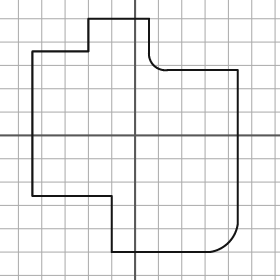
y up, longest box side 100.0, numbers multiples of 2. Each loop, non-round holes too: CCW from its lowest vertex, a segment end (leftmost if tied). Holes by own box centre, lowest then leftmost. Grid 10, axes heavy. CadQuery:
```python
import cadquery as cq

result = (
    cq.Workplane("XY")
    .moveTo(-10.0, -50.0)
    .lineTo(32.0, -50.0)
    .threePointArc((40.0, -46.0), (44.0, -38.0))
    .lineTo(44.0, 28.0)
    .lineTo(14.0, 28.0)
    .threePointArc((8.0, 30.0), (6.0, 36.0))
    .lineTo(6.0, 50.0)
    .lineTo(-20.0, 50.0)
    .lineTo(-20.0, 36.0)
    .lineTo(-44.0, 36.0)
    .lineTo(-44.0, -26.0)
    .lineTo(-10.0, -26.0)
    .close()
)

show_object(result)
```